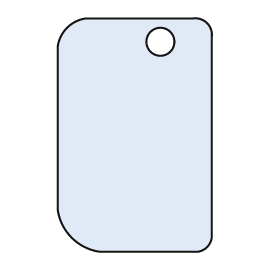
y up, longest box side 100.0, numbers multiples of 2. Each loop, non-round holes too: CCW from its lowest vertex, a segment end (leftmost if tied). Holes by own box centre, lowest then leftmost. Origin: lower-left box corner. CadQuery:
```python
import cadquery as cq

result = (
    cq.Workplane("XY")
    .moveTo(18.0, 0.0)
    .lineTo(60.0, 0.0)
    .threePointArc((64.0, 2.0), (66.0, 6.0))
    .lineTo(66.0, 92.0)
    .threePointArc((64.0, 98.0), (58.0, 100.0))
    .lineTo(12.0, 100.0)
    .threePointArc((4.0, 96.0), (0.0, 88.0))
    .lineTo(0.0, 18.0)
    .threePointArc((6.0, 6.0), (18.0, 0.0))
    .close()
    .moveTo(44.0, 90.0)
    .circle(6.0)
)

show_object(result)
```